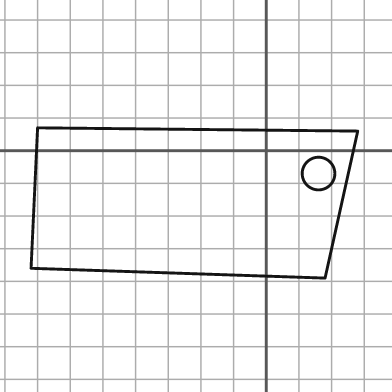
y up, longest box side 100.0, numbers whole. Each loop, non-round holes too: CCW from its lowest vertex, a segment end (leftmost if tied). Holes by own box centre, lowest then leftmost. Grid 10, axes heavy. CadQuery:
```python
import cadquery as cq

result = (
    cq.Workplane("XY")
    .moveTo(18.0, -39.0)
    .lineTo(28.0, 6.0)
    .lineTo(-70.0, 7.0)
    .lineTo(-72.0, -36.0)
    .close()
    .moveTo(16.0, -7.0)
    .circle(5.0)
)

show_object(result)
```